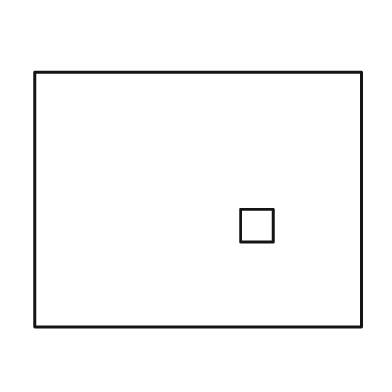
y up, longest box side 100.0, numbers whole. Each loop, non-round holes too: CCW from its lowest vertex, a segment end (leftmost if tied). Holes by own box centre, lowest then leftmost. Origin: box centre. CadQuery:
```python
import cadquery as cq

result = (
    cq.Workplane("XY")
    .moveTo(-50.0, -39.0)
    .lineTo(50.0, -39.0)
    .lineTo(50.0, 39.0)
    .lineTo(-50.0, 39.0)
    .close()
    .moveTo(13.0, -13.0)
    .lineTo(23.0, -13.0)
    .lineTo(23.0, -3.0)
    .lineTo(13.0, -3.0)
    .close()
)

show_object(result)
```